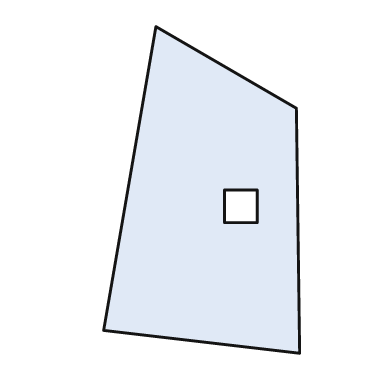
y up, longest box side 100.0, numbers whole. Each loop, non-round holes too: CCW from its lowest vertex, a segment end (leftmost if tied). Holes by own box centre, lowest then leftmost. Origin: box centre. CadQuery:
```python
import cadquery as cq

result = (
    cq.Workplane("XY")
    .moveTo(30.0, -50.0)
    .lineTo(29.0, 25.0)
    .lineTo(-14.0, 50.0)
    .lineTo(-30.0, -43.0)
    .close()
    .moveTo(7.0, -10.0)
    .lineTo(17.0, -10.0)
    .lineTo(17.0, 0.0)
    .lineTo(7.0, 0.0)
    .close()
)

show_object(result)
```